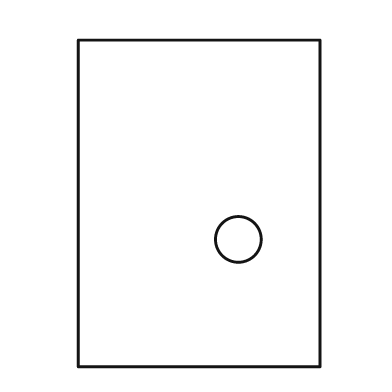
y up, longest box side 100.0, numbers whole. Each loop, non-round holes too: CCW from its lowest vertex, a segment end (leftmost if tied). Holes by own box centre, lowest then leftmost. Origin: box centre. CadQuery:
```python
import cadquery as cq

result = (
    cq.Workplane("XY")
    .moveTo(-37.0, -50.0)
    .lineTo(37.0, -50.0)
    .lineTo(37.0, 50.0)
    .lineTo(-37.0, 50.0)
    .close()
    .moveTo(12.0, -11.0)
    .circle(7.0)
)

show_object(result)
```